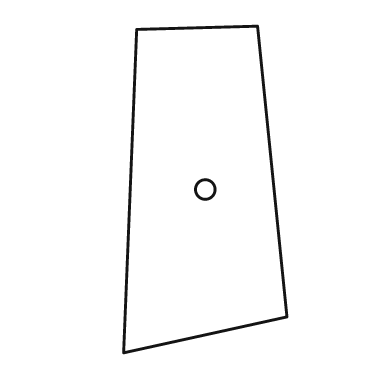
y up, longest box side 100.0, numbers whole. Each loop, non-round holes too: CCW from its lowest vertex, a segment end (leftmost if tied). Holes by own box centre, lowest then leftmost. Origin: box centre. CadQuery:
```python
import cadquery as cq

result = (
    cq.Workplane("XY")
    .moveTo(-25.0, -50.0)
    .lineTo(25.0, -39.0)
    .lineTo(16.0, 50.0)
    .lineTo(-21.0, 49.0)
    .close()
    .moveTo(0.0, 0.0)
    .circle(3.0)
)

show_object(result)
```